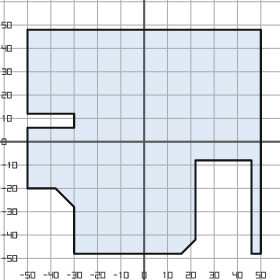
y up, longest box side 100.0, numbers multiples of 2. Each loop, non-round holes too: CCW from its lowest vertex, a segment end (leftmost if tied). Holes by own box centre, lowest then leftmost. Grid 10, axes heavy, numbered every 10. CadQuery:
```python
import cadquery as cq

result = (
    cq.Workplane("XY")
    .moveTo(-30.0, -48.0)
    .lineTo(16.0, -48.0)
    .lineTo(22.0, -42.0)
    .lineTo(22.0, -8.0)
    .lineTo(46.0, -8.0)
    .lineTo(46.0, -48.0)
    .lineTo(50.0, -48.0)
    .lineTo(50.0, 48.0)
    .lineTo(-50.0, 48.0)
    .lineTo(-50.0, 12.0)
    .lineTo(-30.0, 12.0)
    .lineTo(-30.0, 6.0)
    .lineTo(-50.0, 6.0)
    .lineTo(-50.0, -20.0)
    .lineTo(-38.0, -20.0)
    .lineTo(-30.0, -28.0)
    .close()
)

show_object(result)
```